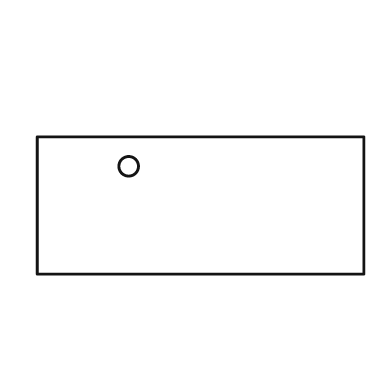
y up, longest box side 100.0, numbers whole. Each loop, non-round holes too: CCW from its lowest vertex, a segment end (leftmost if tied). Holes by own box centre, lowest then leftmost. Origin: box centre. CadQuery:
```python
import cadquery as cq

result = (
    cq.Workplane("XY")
    .moveTo(-50.0, -21.0)
    .lineTo(50.0, -21.0)
    .lineTo(50.0, 21.0)
    .lineTo(-50.0, 21.0)
    .close()
    .moveTo(-22.0, 12.0)
    .circle(3.0)
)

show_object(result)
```